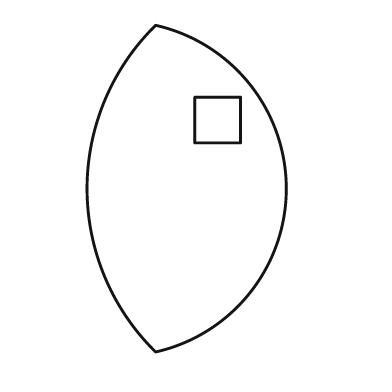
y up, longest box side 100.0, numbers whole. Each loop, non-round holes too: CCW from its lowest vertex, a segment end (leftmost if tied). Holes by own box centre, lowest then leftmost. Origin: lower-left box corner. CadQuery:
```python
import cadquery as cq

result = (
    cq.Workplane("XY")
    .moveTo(21.0, 0.0)
    .threePointArc((61.0, 50.0), (21.0, 100.0))
    .threePointArc((0.0, 50.0), (21.0, 0.0))
    .close()
    .moveTo(33.0, 64.0)
    .lineTo(47.0, 64.0)
    .lineTo(47.0, 78.0)
    .lineTo(33.0, 78.0)
    .close()
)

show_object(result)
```